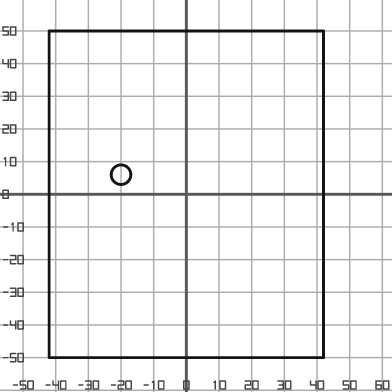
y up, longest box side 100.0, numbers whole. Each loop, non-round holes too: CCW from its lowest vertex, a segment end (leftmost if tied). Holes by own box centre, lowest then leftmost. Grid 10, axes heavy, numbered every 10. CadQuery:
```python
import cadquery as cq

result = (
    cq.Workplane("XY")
    .moveTo(-42.0, -50.0)
    .lineTo(42.0, -50.0)
    .lineTo(42.0, 50.0)
    .lineTo(-42.0, 50.0)
    .close()
    .moveTo(-20.0, 6.0)
    .circle(3.0)
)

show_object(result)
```